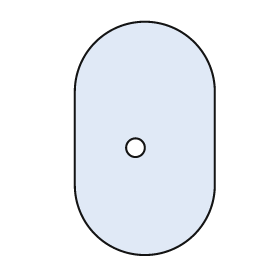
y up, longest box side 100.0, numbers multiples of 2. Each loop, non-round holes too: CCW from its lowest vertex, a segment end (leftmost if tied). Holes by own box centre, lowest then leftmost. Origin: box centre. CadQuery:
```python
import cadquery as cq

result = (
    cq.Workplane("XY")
    .moveTo(-30.0, -20.0)
    .threePointArc((0.0, -50.0), (30.0, -20.0))
    .lineTo(30.0, 20.0)
    .threePointArc((0.0, 50.0), (-30.0, 20.0))
    .close()
    .moveTo(-4.0, -4.0)
    .circle(4.0)
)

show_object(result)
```